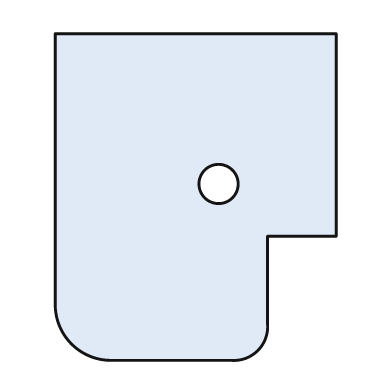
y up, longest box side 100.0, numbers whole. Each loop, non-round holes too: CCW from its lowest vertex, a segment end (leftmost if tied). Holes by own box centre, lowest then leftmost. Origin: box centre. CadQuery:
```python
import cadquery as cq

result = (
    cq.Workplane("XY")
    .moveTo(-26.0, -50.0)
    .lineTo(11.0, -50.0)
    .threePointArc((19.0, -47.0), (22.0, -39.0))
    .lineTo(22.0, -12.0)
    .lineTo(43.0, -12.0)
    .lineTo(43.0, 50.0)
    .lineTo(-43.0, 50.0)
    .lineTo(-43.0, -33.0)
    .threePointArc((-38.0, -45.0), (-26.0, -50.0))
    .close()
    .moveTo(7.0, 4.0)
    .circle(6.0)
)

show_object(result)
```